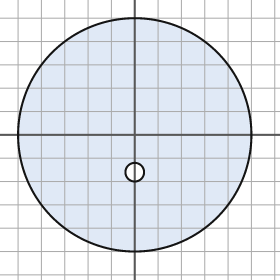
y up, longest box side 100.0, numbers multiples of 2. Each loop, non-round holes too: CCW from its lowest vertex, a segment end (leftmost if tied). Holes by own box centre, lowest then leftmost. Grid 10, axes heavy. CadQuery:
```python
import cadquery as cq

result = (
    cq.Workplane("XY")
    .moveTo(0.0, 0.0)
    .circle(50.0)
    .moveTo(0.0, -16.0)
    .circle(4.0)
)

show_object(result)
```